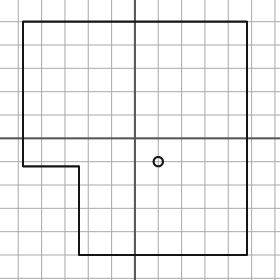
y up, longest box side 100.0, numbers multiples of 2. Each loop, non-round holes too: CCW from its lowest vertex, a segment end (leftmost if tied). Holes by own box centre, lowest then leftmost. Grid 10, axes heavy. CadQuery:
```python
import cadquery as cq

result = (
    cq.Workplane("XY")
    .moveTo(-24.0, -50.0)
    .lineTo(48.0, -50.0)
    .lineTo(48.0, 50.0)
    .lineTo(-48.0, 50.0)
    .lineTo(-48.0, -12.0)
    .lineTo(-24.0, -12.0)
    .close()
    .moveTo(10.0, -10.0)
    .circle(2.0)
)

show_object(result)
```